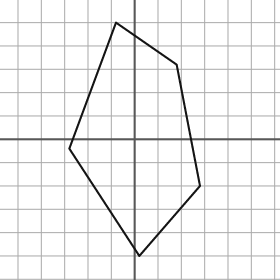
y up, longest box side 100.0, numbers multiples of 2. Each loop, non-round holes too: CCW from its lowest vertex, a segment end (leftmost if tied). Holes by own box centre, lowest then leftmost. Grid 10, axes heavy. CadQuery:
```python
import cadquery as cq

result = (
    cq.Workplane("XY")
    .moveTo(2.0, -50.0)
    .lineTo(28.0, -20.0)
    .lineTo(18.0, 32.0)
    .lineTo(-8.0, 50.0)
    .lineTo(-28.0, -4.0)
    .close()
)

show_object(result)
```